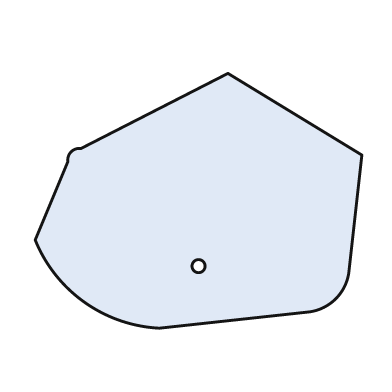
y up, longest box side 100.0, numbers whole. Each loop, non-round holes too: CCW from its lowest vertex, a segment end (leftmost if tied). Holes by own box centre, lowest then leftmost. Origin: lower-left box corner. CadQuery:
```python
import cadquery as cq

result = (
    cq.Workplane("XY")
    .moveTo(38.0, 0.0)
    .lineTo(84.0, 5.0)
    .threePointArc((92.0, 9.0), (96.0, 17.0))
    .lineTo(100.0, 53.0)
    .lineTo(59.0, 78.0)
    .lineTo(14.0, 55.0)
    .threePointArc((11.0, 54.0), (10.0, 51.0))
    .lineTo(0.0, 27.0)
    .threePointArc((15.0, 8.0), (38.0, 0.0))
    .close()
    .moveTo(50.0, 19.0)
    .circle(2.0)
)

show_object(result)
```